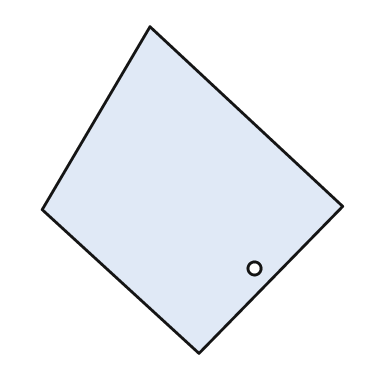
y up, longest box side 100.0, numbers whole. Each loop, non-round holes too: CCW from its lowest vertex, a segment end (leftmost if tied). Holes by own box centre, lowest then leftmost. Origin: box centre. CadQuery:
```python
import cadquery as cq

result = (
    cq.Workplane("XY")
    .moveTo(2.0, -50.0)
    .lineTo(46.0, -5.0)
    .lineTo(-13.0, 50.0)
    .lineTo(-46.0, -6.0)
    .close()
    .moveTo(19.0, -24.0)
    .circle(2.0)
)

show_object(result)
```